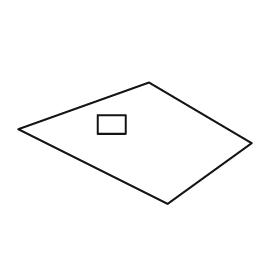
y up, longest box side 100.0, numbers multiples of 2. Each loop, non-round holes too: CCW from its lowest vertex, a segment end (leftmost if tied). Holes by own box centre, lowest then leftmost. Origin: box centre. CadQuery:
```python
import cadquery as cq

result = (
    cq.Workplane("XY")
    .moveTo(14.0, -26.0)
    .lineTo(50.0, 0.0)
    .lineTo(6.0, 26.0)
    .lineTo(-50.0, 6.0)
    .close()
    .moveTo(-16.0, 4.0)
    .lineTo(-4.0, 4.0)
    .lineTo(-4.0, 12.0)
    .lineTo(-16.0, 12.0)
    .close()
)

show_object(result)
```